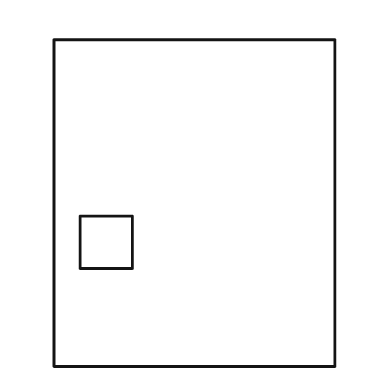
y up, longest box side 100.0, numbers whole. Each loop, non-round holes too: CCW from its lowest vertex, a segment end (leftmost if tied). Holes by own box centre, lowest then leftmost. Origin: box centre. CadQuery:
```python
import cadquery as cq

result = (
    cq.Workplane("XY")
    .moveTo(-43.0, -50.0)
    .lineTo(43.0, -50.0)
    .lineTo(43.0, 50.0)
    .lineTo(-43.0, 50.0)
    .close()
    .moveTo(-35.0, -20.0)
    .lineTo(-19.0, -20.0)
    .lineTo(-19.0, -4.0)
    .lineTo(-35.0, -4.0)
    .close()
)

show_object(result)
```